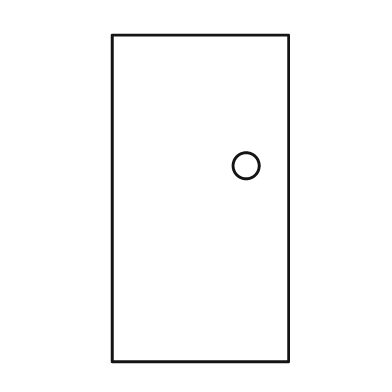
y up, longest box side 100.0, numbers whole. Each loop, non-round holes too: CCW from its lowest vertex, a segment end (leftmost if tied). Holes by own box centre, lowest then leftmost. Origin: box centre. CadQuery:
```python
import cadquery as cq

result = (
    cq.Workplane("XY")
    .moveTo(-27.0, -50.0)
    .lineTo(27.0, -50.0)
    .lineTo(27.0, 50.0)
    .lineTo(-27.0, 50.0)
    .close()
    .moveTo(14.0, 10.0)
    .circle(4.0)
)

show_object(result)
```